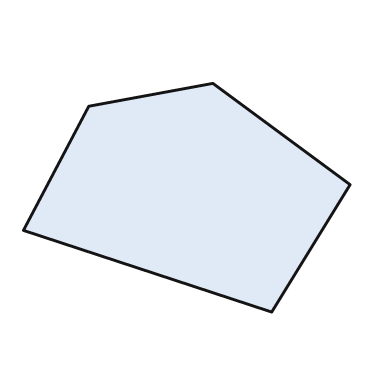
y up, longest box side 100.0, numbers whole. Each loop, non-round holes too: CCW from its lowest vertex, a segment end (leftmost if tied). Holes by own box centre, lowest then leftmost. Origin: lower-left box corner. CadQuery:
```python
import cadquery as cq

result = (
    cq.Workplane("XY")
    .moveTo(76.0, 0.0)
    .lineTo(100.0, 39.0)
    .lineTo(58.0, 70.0)
    .lineTo(20.0, 63.0)
    .lineTo(0.0, 25.0)
    .close()
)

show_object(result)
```